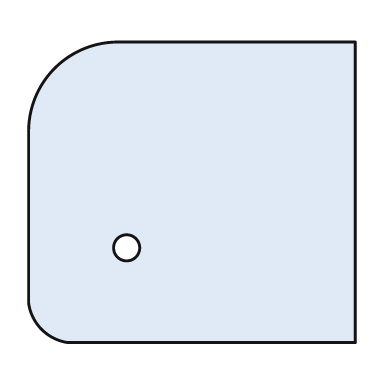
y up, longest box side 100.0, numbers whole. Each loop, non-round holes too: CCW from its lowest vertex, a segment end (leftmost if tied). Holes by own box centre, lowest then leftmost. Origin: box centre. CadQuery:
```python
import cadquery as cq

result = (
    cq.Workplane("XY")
    .moveTo(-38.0, -46.0)
    .lineTo(50.0, -46.0)
    .lineTo(50.0, 46.0)
    .lineTo(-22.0, 46.0)
    .threePointArc((-42.0, 38.0), (-50.0, 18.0))
    .lineTo(-50.0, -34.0)
    .threePointArc((-46.0, -42.0), (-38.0, -46.0))
    .close()
    .moveTo(-20.0, -17.0)
    .circle(4.0)
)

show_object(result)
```